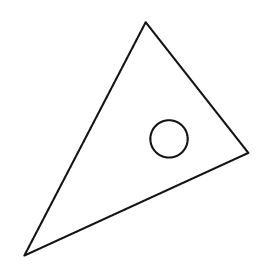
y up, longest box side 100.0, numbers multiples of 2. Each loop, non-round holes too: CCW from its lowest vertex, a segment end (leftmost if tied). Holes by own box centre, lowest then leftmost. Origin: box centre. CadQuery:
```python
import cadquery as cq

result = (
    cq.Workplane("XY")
    .moveTo(-48.0, -50.0)
    .lineTo(48.0, -6.0)
    .lineTo(4.0, 50.0)
    .close()
    .moveTo(14.0, 0.0)
    .circle(8.0)
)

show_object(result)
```